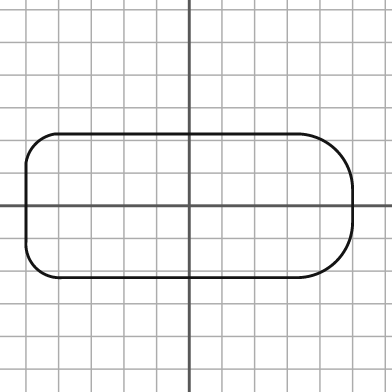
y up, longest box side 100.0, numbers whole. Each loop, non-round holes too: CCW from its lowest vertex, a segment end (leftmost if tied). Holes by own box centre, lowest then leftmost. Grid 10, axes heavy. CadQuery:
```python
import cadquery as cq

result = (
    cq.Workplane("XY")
    .moveTo(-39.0, -22.0)
    .lineTo(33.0, -22.0)
    .threePointArc((45.0, -17.0), (50.0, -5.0))
    .lineTo(50.0, 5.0)
    .threePointArc((45.0, 17.0), (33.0, 22.0))
    .lineTo(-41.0, 22.0)
    .threePointArc((-47.0, 19.0), (-50.0, 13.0))
    .lineTo(-50.0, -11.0)
    .threePointArc((-47.0, -19.0), (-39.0, -22.0))
    .close()
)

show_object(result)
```